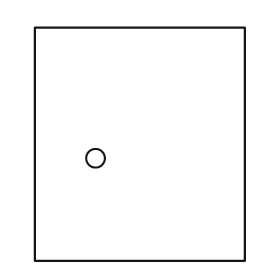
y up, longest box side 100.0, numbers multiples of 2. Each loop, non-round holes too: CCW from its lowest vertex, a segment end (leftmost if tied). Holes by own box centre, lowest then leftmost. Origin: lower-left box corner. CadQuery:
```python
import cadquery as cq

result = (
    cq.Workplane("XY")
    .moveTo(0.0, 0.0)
    .lineTo(90.0, 0.0)
    .lineTo(90.0, 100.0)
    .lineTo(0.0, 100.0)
    .close()
    .moveTo(26.0, 44.0)
    .circle(4.0)
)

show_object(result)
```